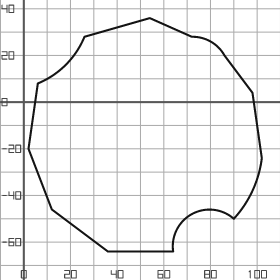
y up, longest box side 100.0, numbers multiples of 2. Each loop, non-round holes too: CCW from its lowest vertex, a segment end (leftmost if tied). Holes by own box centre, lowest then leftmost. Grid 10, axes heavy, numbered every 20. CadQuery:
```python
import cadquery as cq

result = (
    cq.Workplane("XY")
    .moveTo(36.0, -64.0)
    .lineTo(64.0, -64.0)
    .threePointArc((72.0, -48.0), (90.0, -50.0))
    .threePointArc((98.0, -38.0), (102.0, -24.0))
    .lineTo(98.0, 4.0)
    .lineTo(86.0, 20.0)
    .threePointArc((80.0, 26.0), (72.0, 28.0))
    .lineTo(54.0, 36.0)
    .lineTo(26.0, 28.0)
    .threePointArc((18.0, 16.0), (6.0, 8.0))
    .lineTo(2.0, -20.0)
    .lineTo(12.0, -46.0)
    .close()
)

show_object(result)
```